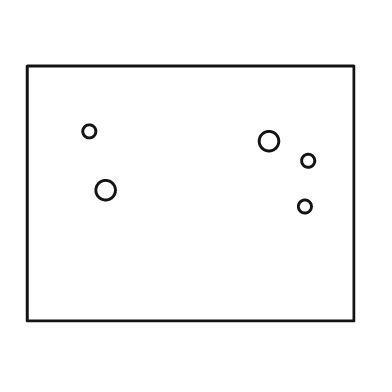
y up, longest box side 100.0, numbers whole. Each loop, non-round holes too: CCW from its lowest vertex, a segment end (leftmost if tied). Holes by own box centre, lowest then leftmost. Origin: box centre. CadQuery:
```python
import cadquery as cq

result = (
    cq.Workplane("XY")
    .moveTo(-50.0, -39.0)
    .lineTo(50.0, -39.0)
    .lineTo(50.0, 39.0)
    .lineTo(-50.0, 39.0)
    .close()
    .moveTo(35.0, -4.0)
    .circle(2.0)
    .moveTo(-26.0, 1.0)
    .circle(3.0)
    .moveTo(36.0, 10.0)
    .circle(2.0)
    .moveTo(24.0, 16.0)
    .circle(3.0)
    .moveTo(-31.0, 19.0)
    .circle(2.0)
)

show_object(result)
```